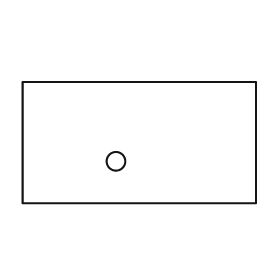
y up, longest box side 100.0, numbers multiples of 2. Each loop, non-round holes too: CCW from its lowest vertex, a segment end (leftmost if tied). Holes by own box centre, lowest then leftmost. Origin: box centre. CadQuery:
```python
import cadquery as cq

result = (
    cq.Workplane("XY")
    .moveTo(-50.0, -26.0)
    .lineTo(50.0, -26.0)
    .lineTo(50.0, 26.0)
    .lineTo(-50.0, 26.0)
    .close()
    .moveTo(-10.0, -8.0)
    .circle(4.0)
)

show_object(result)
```